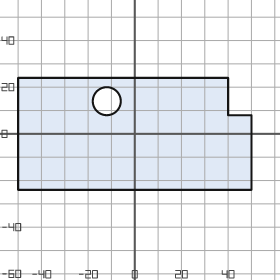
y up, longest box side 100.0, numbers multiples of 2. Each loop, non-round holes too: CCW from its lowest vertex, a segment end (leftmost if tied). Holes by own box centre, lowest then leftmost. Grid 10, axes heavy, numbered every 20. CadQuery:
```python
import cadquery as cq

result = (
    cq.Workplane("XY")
    .moveTo(-50.0, -24.0)
    .lineTo(50.0, -24.0)
    .lineTo(50.0, 8.0)
    .lineTo(40.0, 8.0)
    .lineTo(40.0, 24.0)
    .lineTo(-50.0, 24.0)
    .close()
    .moveTo(-12.0, 14.0)
    .circle(6.0)
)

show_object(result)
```